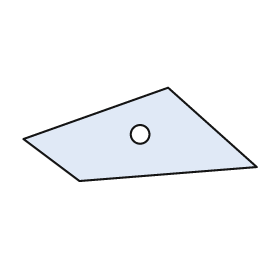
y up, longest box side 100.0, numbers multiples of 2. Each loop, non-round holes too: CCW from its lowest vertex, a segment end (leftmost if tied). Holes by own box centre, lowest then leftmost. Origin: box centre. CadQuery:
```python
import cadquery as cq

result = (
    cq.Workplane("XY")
    .moveTo(-26.0, -20.0)
    .lineTo(50.0, -14.0)
    .lineTo(12.0, 20.0)
    .lineTo(-50.0, -2.0)
    .close()
    .moveTo(0.0, 0.0)
    .circle(4.0)
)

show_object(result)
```